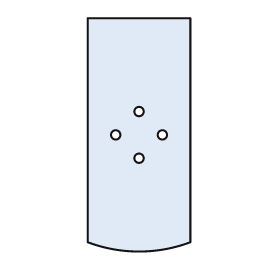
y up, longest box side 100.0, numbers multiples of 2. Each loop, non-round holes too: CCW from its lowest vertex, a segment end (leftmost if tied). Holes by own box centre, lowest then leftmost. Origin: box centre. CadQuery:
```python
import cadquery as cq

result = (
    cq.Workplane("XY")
    .moveTo(-22.0, -46.0)
    .threePointArc((0.0, -50.0), (22.0, -46.0))
    .lineTo(22.0, 50.0)
    .lineTo(-22.0, 50.0)
    .close()
    .moveTo(0.0, -10.0)
    .circle(2.0)
    .moveTo(-10.0, 0.0)
    .circle(2.0)
    .moveTo(10.0, 0.0)
    .circle(2.0)
    .moveTo(0.0, 10.0)
    .circle(2.0)
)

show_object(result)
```